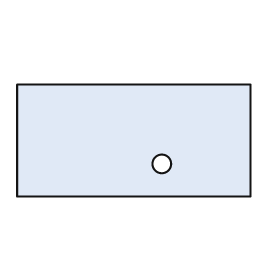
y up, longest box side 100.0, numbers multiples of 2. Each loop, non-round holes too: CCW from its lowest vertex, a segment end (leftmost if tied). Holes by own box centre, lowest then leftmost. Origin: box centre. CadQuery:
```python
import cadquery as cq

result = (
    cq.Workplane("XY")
    .moveTo(-50.0, -24.0)
    .lineTo(50.0, -24.0)
    .lineTo(50.0, 24.0)
    .lineTo(-50.0, 24.0)
    .close()
    .moveTo(12.0, -10.0)
    .circle(4.0)
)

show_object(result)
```